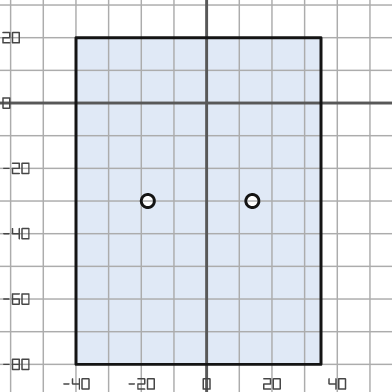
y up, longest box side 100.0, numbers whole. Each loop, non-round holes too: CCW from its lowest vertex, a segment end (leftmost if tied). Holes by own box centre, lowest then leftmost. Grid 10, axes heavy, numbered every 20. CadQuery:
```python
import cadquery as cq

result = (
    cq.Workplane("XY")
    .moveTo(-40.0, -80.0)
    .lineTo(35.0, -80.0)
    .lineTo(35.0, 20.0)
    .lineTo(-40.0, 20.0)
    .close()
    .moveTo(-18.0, -30.0)
    .circle(2.0)
    .moveTo(14.0, -30.0)
    .circle(2.0)
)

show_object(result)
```